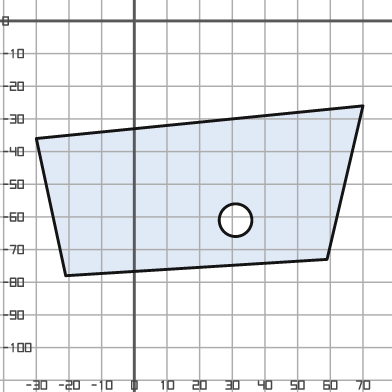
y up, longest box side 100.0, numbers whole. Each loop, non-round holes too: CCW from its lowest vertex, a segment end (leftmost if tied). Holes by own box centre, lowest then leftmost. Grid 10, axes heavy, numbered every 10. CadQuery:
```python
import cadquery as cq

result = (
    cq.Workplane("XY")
    .moveTo(-21.0, -78.0)
    .lineTo(59.0, -73.0)
    .lineTo(70.0, -26.0)
    .lineTo(-30.0, -36.0)
    .close()
    .moveTo(31.0, -61.0)
    .circle(5.0)
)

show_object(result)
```